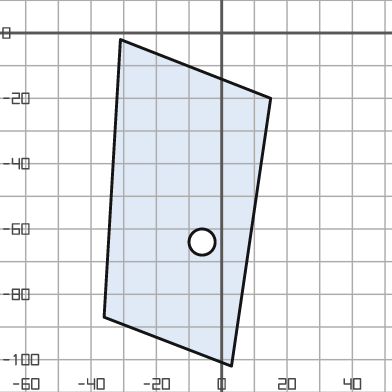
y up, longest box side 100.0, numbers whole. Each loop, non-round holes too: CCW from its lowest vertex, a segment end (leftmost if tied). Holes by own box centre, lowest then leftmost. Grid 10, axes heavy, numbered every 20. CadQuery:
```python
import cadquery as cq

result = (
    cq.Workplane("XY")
    .moveTo(3.0, -102.0)
    .lineTo(15.0, -20.0)
    .lineTo(-31.0, -2.0)
    .lineTo(-36.0, -87.0)
    .close()
    .moveTo(-6.0, -64.0)
    .circle(4.0)
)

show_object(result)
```